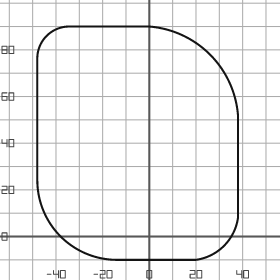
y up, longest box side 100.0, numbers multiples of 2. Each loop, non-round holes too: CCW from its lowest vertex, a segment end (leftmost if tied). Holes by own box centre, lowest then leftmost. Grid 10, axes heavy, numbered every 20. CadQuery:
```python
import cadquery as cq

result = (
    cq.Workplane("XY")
    .moveTo(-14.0, -10.0)
    .lineTo(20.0, -10.0)
    .threePointArc((32.0, -4.0), (38.0, 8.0))
    .lineTo(38.0, 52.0)
    .threePointArc((26.0, 78.0), (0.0, 90.0))
    .lineTo(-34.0, 90.0)
    .threePointArc((-44.0, 86.0), (-48.0, 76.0))
    .lineTo(-48.0, 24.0)
    .threePointArc((-38.0, 0.0), (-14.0, -10.0))
    .close()
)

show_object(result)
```